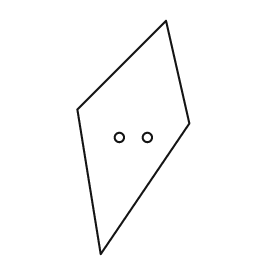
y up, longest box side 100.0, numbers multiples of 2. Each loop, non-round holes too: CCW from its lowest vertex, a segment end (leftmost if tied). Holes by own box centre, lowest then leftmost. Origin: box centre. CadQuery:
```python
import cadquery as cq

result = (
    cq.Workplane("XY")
    .moveTo(-14.0, -50.0)
    .lineTo(24.0, 6.0)
    .lineTo(14.0, 50.0)
    .lineTo(-24.0, 12.0)
    .close()
    .moveTo(-6.0, 0.0)
    .circle(2.0)
    .moveTo(6.0, 0.0)
    .circle(2.0)
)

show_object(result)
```